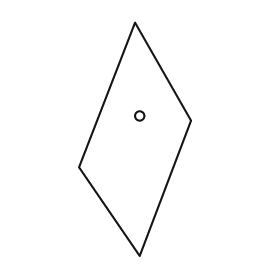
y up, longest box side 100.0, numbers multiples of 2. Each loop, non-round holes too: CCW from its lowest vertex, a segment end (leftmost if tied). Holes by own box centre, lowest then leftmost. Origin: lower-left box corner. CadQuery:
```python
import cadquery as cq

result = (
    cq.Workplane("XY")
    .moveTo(26.0, 0.0)
    .lineTo(48.0, 58.0)
    .lineTo(24.0, 100.0)
    .lineTo(0.0, 38.0)
    .close()
    .moveTo(26.0, 60.0)
    .circle(2.0)
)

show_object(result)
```